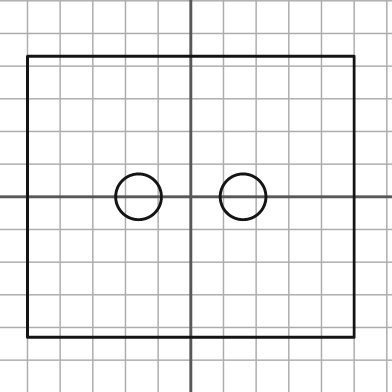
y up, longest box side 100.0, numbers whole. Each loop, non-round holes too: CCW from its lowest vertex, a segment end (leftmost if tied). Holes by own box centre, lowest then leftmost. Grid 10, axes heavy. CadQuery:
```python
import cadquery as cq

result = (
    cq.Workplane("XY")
    .moveTo(-50.0, -43.0)
    .lineTo(50.0, -43.0)
    .lineTo(50.0, 43.0)
    .lineTo(-50.0, 43.0)
    .close()
    .moveTo(-16.0, 0.0)
    .circle(7.0)
    .moveTo(16.0, 0.0)
    .circle(7.0)
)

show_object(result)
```